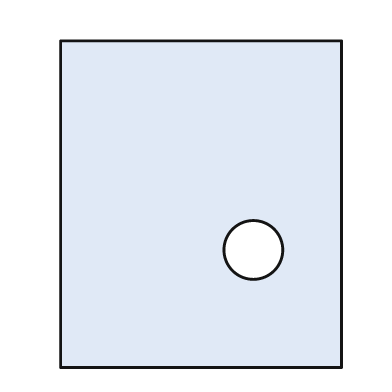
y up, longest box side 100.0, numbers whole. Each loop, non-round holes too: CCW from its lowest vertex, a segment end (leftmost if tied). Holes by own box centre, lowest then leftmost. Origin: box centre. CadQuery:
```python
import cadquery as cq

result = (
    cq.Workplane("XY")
    .moveTo(-43.0, -50.0)
    .lineTo(43.0, -50.0)
    .lineTo(43.0, 50.0)
    .lineTo(-43.0, 50.0)
    .close()
    .moveTo(16.0, -14.0)
    .circle(9.0)
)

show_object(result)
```